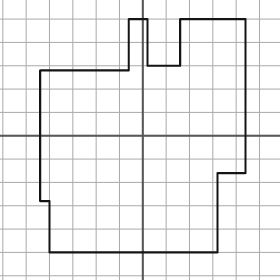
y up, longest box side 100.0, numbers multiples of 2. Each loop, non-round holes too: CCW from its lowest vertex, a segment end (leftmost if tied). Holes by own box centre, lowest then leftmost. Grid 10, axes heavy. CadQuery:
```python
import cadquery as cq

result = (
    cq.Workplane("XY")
    .moveTo(-40.0, -50.0)
    .lineTo(32.0, -50.0)
    .lineTo(32.0, -16.0)
    .lineTo(44.0, -16.0)
    .lineTo(44.0, 50.0)
    .lineTo(16.0, 50.0)
    .lineTo(16.0, 30.0)
    .lineTo(2.0, 30.0)
    .lineTo(2.0, 50.0)
    .lineTo(-6.0, 50.0)
    .lineTo(-6.0, 28.0)
    .lineTo(-44.0, 28.0)
    .lineTo(-44.0, -28.0)
    .lineTo(-40.0, -28.0)
    .close()
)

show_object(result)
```